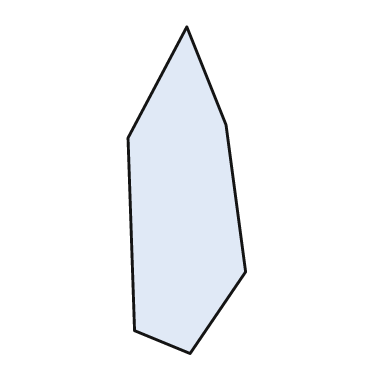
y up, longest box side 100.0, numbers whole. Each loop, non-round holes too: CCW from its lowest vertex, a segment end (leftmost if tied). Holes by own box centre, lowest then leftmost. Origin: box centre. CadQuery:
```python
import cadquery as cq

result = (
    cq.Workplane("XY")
    .moveTo(1.0, -50.0)
    .lineTo(18.0, -25.0)
    .lineTo(12.0, 20.0)
    .lineTo(0.0, 50.0)
    .lineTo(-18.0, 16.0)
    .lineTo(-16.0, -43.0)
    .close()
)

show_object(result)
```